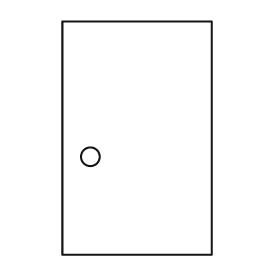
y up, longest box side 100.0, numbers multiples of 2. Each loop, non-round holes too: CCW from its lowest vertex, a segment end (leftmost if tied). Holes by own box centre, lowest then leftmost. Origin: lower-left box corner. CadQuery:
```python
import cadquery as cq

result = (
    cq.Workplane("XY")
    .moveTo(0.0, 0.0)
    .lineTo(64.0, 0.0)
    .lineTo(64.0, 100.0)
    .lineTo(0.0, 100.0)
    .close()
    .moveTo(12.0, 42.0)
    .circle(4.0)
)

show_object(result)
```